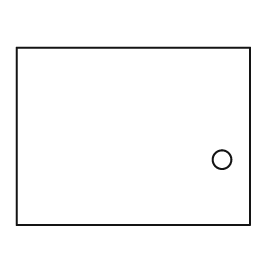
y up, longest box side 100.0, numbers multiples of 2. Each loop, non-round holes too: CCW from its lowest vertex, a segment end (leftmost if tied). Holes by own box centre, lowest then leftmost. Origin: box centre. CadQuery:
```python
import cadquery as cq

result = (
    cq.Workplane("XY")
    .moveTo(-50.0, -38.0)
    .lineTo(50.0, -38.0)
    .lineTo(50.0, 38.0)
    .lineTo(-50.0, 38.0)
    .close()
    .moveTo(38.0, -10.0)
    .circle(4.0)
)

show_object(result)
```